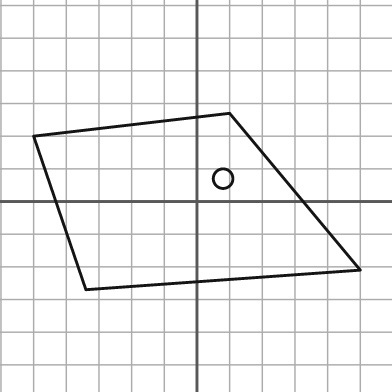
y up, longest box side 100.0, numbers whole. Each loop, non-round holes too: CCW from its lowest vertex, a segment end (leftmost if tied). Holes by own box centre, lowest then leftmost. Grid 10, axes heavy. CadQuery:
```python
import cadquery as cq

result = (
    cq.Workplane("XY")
    .moveTo(-34.0, -27.0)
    .lineTo(50.0, -21.0)
    .lineTo(10.0, 27.0)
    .lineTo(-50.0, 20.0)
    .close()
    .moveTo(8.0, 7.0)
    .circle(3.0)
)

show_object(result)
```